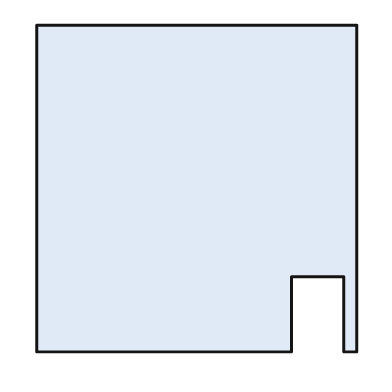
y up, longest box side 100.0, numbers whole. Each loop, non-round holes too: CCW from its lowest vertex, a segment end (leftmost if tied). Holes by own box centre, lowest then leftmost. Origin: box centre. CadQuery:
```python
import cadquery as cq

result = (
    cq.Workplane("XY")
    .moveTo(-49.0, -50.0)
    .lineTo(29.0, -50.0)
    .lineTo(29.0, -27.0)
    .lineTo(45.0, -27.0)
    .lineTo(45.0, -50.0)
    .lineTo(49.0, -50.0)
    .lineTo(49.0, 50.0)
    .lineTo(-49.0, 50.0)
    .close()
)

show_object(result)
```